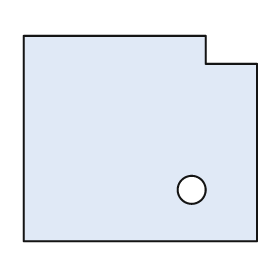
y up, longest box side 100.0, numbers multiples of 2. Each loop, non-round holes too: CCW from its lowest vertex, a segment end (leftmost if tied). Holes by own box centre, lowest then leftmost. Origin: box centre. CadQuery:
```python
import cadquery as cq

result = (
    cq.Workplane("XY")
    .moveTo(-50.0, -44.0)
    .lineTo(50.0, -44.0)
    .lineTo(50.0, 32.0)
    .lineTo(28.0, 32.0)
    .lineTo(28.0, 44.0)
    .lineTo(-50.0, 44.0)
    .close()
    .moveTo(22.0, -22.0)
    .circle(6.0)
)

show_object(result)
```